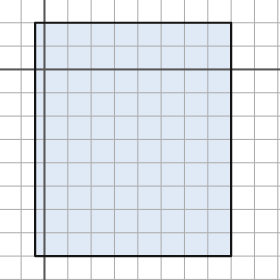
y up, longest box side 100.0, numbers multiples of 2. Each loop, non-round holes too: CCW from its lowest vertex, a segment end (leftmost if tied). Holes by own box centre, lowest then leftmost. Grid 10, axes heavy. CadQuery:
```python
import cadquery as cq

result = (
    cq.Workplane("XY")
    .moveTo(-4.0, -80.0)
    .lineTo(80.0, -80.0)
    .lineTo(80.0, 20.0)
    .lineTo(-4.0, 20.0)
    .close()
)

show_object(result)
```